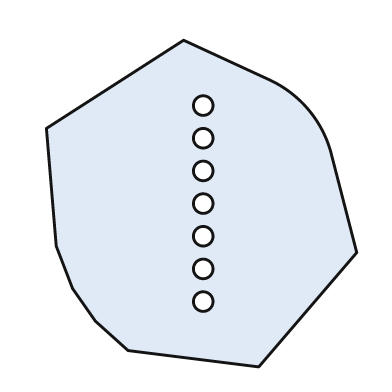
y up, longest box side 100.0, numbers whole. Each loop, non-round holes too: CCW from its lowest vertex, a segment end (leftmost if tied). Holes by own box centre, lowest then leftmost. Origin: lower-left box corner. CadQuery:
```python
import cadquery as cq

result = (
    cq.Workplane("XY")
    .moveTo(65.0, 0.0)
    .lineTo(95.0, 35.0)
    .lineTo(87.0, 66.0)
    .threePointArc((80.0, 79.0), (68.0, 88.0))
    .lineTo(42.0, 100.0)
    .lineTo(0.0, 73.0)
    .lineTo(3.0, 37.0)
    .lineTo(8.0, 24.0)
    .lineTo(15.0, 14.0)
    .lineTo(25.0, 5.0)
    .close()
    .moveTo(48.0, 20.0)
    .circle(3.0)
    .moveTo(48.0, 30.0)
    .circle(3.0)
    .moveTo(48.0, 40.0)
    .circle(3.0)
    .moveTo(48.0, 50.0)
    .circle(3.0)
    .moveTo(48.0, 60.0)
    .circle(3.0)
    .moveTo(48.0, 70.0)
    .circle(3.0)
    .moveTo(48.0, 80.0)
    .circle(3.0)
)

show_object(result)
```